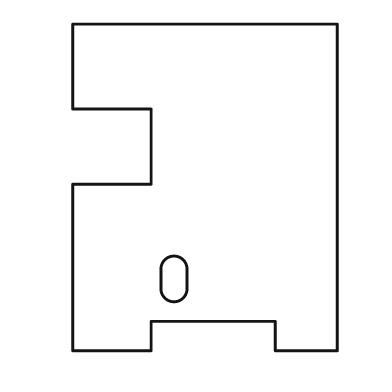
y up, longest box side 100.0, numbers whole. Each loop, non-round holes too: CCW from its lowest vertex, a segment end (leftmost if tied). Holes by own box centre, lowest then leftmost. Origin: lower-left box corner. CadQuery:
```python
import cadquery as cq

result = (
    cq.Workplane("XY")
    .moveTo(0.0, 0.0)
    .lineTo(24.0, 0.0)
    .lineTo(24.0, 9.0)
    .lineTo(62.0, 9.0)
    .lineTo(62.0, 0.0)
    .lineTo(81.0, 0.0)
    .lineTo(81.0, 100.0)
    .lineTo(0.0, 100.0)
    .lineTo(0.0, 74.0)
    .lineTo(24.0, 74.0)
    .lineTo(24.0, 51.0)
    .lineTo(0.0, 51.0)
    .close()
    .moveTo(27.0, 19.0)
    .threePointArc((31.0, 15.0), (35.0, 19.0))
    .lineTo(35.0, 25.0)
    .threePointArc((31.0, 29.0), (27.0, 25.0))
    .close()
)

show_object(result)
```